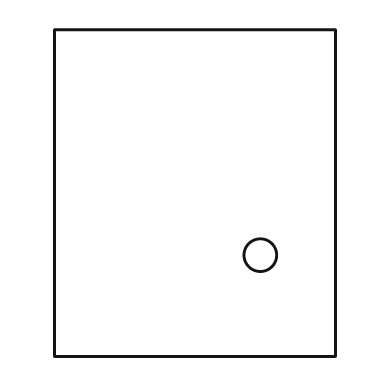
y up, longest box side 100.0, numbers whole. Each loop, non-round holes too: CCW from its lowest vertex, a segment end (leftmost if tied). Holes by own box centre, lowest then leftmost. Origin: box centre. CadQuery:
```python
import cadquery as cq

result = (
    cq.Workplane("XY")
    .moveTo(-43.0, -50.0)
    .lineTo(43.0, -50.0)
    .lineTo(43.0, 50.0)
    .lineTo(-43.0, 50.0)
    .close()
    .moveTo(20.0, -19.0)
    .circle(5.0)
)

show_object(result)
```